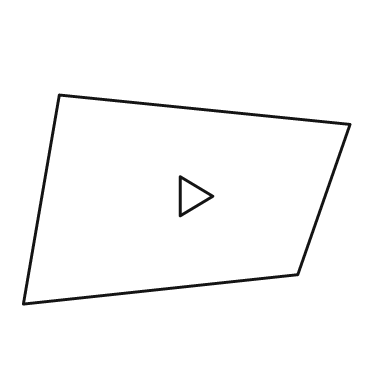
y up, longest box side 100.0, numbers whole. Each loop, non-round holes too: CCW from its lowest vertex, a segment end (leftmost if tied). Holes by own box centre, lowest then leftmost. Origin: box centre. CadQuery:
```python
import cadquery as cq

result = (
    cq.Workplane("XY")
    .moveTo(-50.0, -32.0)
    .lineTo(34.0, -23.0)
    .lineTo(50.0, 23.0)
    .lineTo(-39.0, 32.0)
    .close()
    .moveTo(-2.0, -5.0)
    .lineTo(8.0, 1.0)
    .lineTo(-2.0, 7.0)
    .close()
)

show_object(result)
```